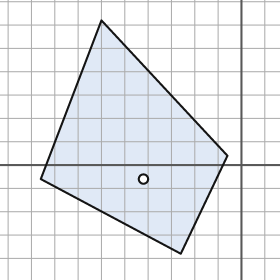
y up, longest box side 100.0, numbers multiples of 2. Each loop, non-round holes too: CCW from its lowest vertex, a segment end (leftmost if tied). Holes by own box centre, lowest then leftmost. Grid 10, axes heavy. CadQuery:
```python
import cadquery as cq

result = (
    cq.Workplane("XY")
    .moveTo(-26.0, -38.0)
    .lineTo(-6.0, 4.0)
    .lineTo(-60.0, 62.0)
    .lineTo(-86.0, -6.0)
    .close()
    .moveTo(-42.0, -6.0)
    .circle(2.0)
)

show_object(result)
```